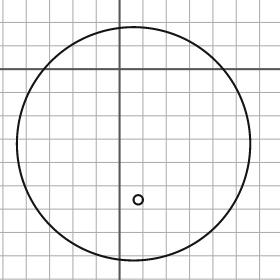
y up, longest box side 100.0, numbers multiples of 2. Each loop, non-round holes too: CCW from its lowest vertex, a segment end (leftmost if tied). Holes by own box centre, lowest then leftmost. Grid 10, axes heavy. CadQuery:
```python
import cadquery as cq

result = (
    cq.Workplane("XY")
    .moveTo(6.0, -32.0)
    .circle(50.0)
    .moveTo(8.0, -56.0)
    .circle(2.0)
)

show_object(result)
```